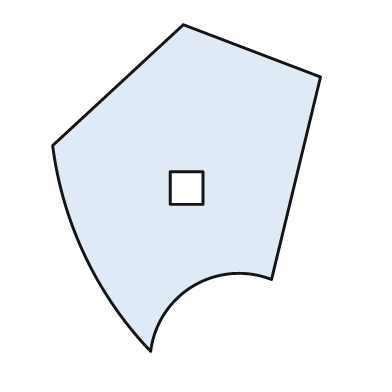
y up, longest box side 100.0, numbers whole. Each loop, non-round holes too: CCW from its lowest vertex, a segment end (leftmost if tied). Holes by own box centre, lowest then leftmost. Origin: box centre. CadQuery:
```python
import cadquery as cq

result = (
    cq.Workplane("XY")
    .moveTo(-11.0, -50.0)
    .threePointArc((2.0, -30.0), (26.0, -28.0))
    .lineTo(41.0, 34.0)
    .lineTo(-1.0, 50.0)
    .lineTo(-41.0, 13.0)
    .threePointArc((-31.0, -21.0), (-11.0, -50.0))
    .close()
    .moveTo(-5.0, -5.0)
    .lineTo(5.0, -5.0)
    .lineTo(5.0, 5.0)
    .lineTo(-5.0, 5.0)
    .close()
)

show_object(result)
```